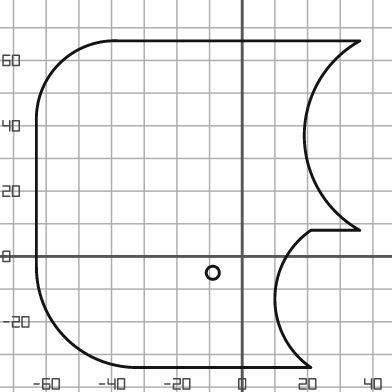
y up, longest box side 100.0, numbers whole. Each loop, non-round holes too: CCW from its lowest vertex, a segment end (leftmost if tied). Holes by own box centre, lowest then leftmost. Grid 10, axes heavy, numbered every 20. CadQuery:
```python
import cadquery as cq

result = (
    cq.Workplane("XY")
    .moveTo(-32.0, -34.0)
    .lineTo(21.0, -34.0)
    .threePointArc((10.0, -13.0), (21.0, 8.0))
    .lineTo(36.0, 8.0)
    .threePointArc((19.0, 37.0), (36.0, 66.0))
    .lineTo(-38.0, 66.0)
    .threePointArc((-56.0, 59.0), (-63.0, 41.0))
    .lineTo(-63.0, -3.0)
    .threePointArc((-54.0, -25.0), (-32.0, -34.0))
    .close()
    .moveTo(-9.0, -5.0)
    .circle(2.0)
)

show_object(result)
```